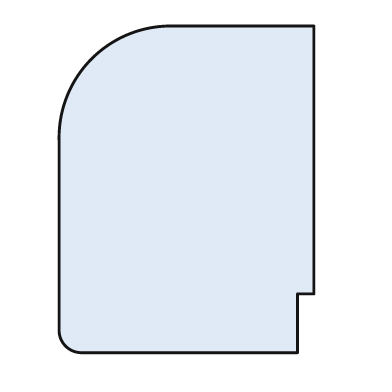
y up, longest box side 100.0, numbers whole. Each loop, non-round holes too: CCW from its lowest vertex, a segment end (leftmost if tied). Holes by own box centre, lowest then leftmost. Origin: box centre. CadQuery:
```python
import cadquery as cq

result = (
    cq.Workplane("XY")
    .moveTo(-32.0, -50.0)
    .lineTo(34.0, -50.0)
    .lineTo(34.0, -32.0)
    .lineTo(39.0, -32.0)
    .lineTo(39.0, 50.0)
    .lineTo(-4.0, 50.0)
    .threePointArc((-29.0, 40.0), (-39.0, 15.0))
    .lineTo(-39.0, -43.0)
    .threePointArc((-37.0, -48.0), (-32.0, -50.0))
    .close()
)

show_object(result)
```